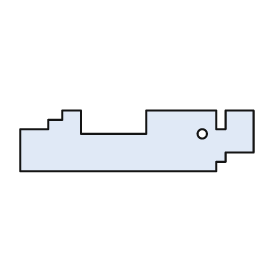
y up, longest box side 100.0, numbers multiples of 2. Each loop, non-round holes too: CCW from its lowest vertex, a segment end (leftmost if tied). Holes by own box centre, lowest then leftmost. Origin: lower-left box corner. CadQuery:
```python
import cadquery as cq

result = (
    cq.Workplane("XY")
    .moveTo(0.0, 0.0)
    .lineTo(84.0, 0.0)
    .lineTo(84.0, 4.0)
    .lineTo(88.0, 4.0)
    .lineTo(88.0, 8.0)
    .lineTo(100.0, 8.0)
    .lineTo(100.0, 26.0)
    .lineTo(88.0, 26.0)
    .lineTo(88.0, 18.0)
    .lineTo(84.0, 18.0)
    .lineTo(84.0, 26.0)
    .lineTo(54.0, 26.0)
    .lineTo(54.0, 16.0)
    .lineTo(26.0, 16.0)
    .lineTo(26.0, 26.0)
    .lineTo(18.0, 26.0)
    .lineTo(18.0, 22.0)
    .lineTo(12.0, 22.0)
    .lineTo(12.0, 18.0)
    .lineTo(0.0, 18.0)
    .close()
    .moveTo(78.0, 16.0)
    .circle(2.0)
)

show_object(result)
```